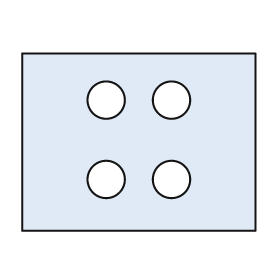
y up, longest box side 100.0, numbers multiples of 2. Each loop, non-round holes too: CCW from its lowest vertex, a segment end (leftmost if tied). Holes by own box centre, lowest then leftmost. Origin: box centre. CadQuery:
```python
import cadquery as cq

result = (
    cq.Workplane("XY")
    .moveTo(-50.0, -38.0)
    .lineTo(50.0, -38.0)
    .lineTo(50.0, 38.0)
    .lineTo(-50.0, 38.0)
    .close()
    .moveTo(-14.0, -16.0)
    .circle(8.0)
    .moveTo(14.0, -16.0)
    .circle(8.0)
    .moveTo(-14.0, 18.0)
    .circle(8.0)
    .moveTo(14.0, 18.0)
    .circle(8.0)
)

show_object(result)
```